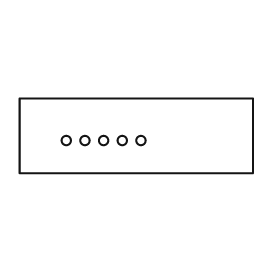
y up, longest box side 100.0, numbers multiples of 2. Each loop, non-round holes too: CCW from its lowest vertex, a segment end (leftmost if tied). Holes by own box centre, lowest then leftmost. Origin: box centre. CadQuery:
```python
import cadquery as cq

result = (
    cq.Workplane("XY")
    .moveTo(-50.0, -16.0)
    .lineTo(50.0, -16.0)
    .lineTo(50.0, 16.0)
    .lineTo(-50.0, 16.0)
    .close()
    .moveTo(-30.0, -2.0)
    .circle(2.0)
    .moveTo(-22.0, -2.0)
    .circle(2.0)
    .moveTo(-14.0, -2.0)
    .circle(2.0)
    .moveTo(-6.0, -2.0)
    .circle(2.0)
    .moveTo(2.0, -2.0)
    .circle(2.0)
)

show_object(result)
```